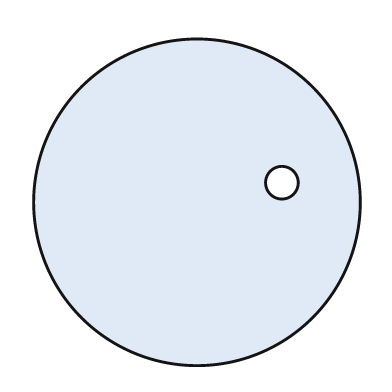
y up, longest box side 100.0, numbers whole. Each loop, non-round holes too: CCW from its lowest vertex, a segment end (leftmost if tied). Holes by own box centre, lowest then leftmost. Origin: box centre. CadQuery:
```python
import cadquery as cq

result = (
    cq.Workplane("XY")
    .moveTo(0.0, 0.0)
    .circle(50.0)
    .moveTo(26.0, 6.0)
    .circle(5.0)
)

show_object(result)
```